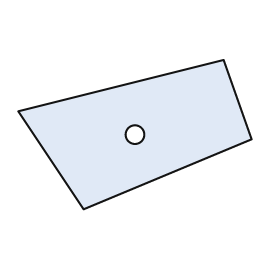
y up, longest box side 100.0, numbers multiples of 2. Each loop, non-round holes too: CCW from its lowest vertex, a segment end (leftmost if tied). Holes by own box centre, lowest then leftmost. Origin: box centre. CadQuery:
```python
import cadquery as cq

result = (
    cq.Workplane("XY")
    .moveTo(-22.0, -32.0)
    .lineTo(50.0, -2.0)
    .lineTo(38.0, 32.0)
    .lineTo(-50.0, 10.0)
    .close()
    .moveTo(0.0, 0.0)
    .circle(4.0)
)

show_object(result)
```